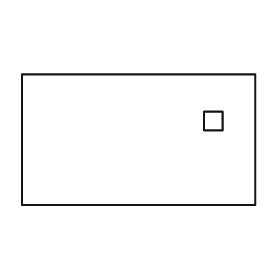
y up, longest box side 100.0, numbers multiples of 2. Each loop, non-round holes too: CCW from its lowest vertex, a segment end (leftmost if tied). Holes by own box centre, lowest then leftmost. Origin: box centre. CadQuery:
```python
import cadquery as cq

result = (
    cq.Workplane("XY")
    .moveTo(-50.0, -28.0)
    .lineTo(50.0, -28.0)
    .lineTo(50.0, 28.0)
    .lineTo(-50.0, 28.0)
    .close()
    .moveTo(28.0, 4.0)
    .lineTo(36.0, 4.0)
    .lineTo(36.0, 12.0)
    .lineTo(28.0, 12.0)
    .close()
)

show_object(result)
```